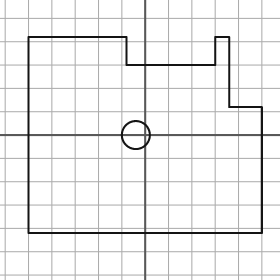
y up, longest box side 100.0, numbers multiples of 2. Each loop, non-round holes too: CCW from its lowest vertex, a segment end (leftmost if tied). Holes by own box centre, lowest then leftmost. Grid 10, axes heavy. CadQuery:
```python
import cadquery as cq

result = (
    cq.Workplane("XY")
    .moveTo(-50.0, -42.0)
    .lineTo(50.0, -42.0)
    .lineTo(50.0, 12.0)
    .lineTo(36.0, 12.0)
    .lineTo(36.0, 42.0)
    .lineTo(30.0, 42.0)
    .lineTo(30.0, 30.0)
    .lineTo(-8.0, 30.0)
    .lineTo(-8.0, 42.0)
    .lineTo(-50.0, 42.0)
    .close()
    .moveTo(-4.0, 0.0)
    .circle(6.0)
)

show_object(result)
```